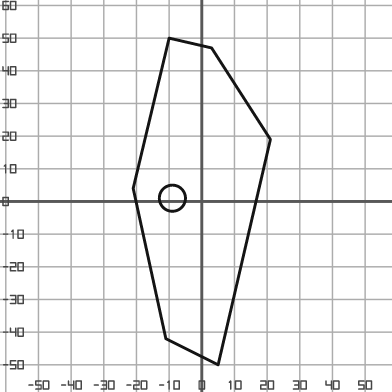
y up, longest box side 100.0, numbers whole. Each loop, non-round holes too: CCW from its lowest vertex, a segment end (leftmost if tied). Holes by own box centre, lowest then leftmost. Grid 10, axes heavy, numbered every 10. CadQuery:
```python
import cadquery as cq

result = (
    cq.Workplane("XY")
    .moveTo(5.0, -50.0)
    .lineTo(21.0, 19.0)
    .lineTo(3.0, 47.0)
    .lineTo(-10.0, 50.0)
    .lineTo(-21.0, 4.0)
    .lineTo(-11.0, -42.0)
    .close()
    .moveTo(-9.0, 1.0)
    .circle(4.0)
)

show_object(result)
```